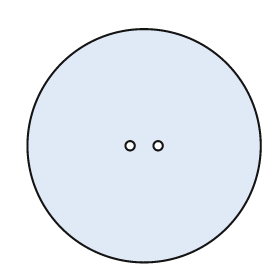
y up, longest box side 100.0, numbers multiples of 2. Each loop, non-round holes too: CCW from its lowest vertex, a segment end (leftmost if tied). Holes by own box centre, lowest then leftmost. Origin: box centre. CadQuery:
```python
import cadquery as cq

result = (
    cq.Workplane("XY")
    .moveTo(0.0, 0.0)
    .circle(50.0)
    .moveTo(-6.0, 0.0)
    .circle(2.0)
    .moveTo(6.0, 0.0)
    .circle(2.0)
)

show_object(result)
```